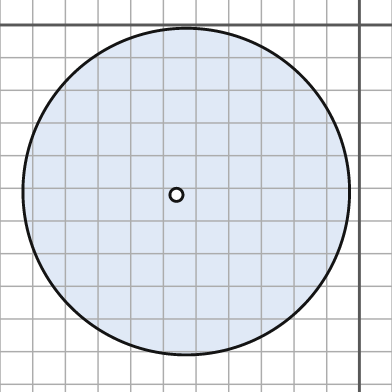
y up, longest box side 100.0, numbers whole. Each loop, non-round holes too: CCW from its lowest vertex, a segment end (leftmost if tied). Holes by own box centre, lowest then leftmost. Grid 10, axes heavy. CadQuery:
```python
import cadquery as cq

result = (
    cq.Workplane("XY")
    .moveTo(-53.0, -51.0)
    .circle(50.0)
    .moveTo(-56.0, -52.0)
    .circle(2.0)
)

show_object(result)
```